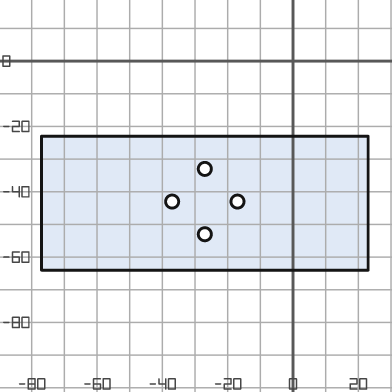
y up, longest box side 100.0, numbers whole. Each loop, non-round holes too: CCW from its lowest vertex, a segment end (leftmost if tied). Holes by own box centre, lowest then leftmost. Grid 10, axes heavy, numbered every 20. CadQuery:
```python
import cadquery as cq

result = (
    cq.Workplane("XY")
    .moveTo(-77.0, -64.0)
    .lineTo(23.0, -64.0)
    .lineTo(23.0, -23.0)
    .lineTo(-77.0, -23.0)
    .close()
    .moveTo(-27.0, -53.0)
    .circle(2.0)
    .moveTo(-37.0, -43.0)
    .circle(2.0)
    .moveTo(-17.0, -43.0)
    .circle(2.0)
    .moveTo(-27.0, -33.0)
    .circle(2.0)
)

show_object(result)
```